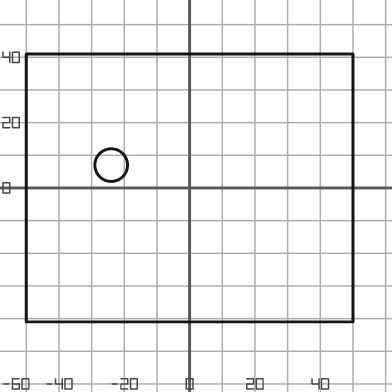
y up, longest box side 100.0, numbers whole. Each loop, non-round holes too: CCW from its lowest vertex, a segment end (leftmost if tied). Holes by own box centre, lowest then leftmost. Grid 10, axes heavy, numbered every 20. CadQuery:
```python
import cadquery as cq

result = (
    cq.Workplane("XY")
    .moveTo(-50.0, -41.0)
    .lineTo(50.0, -41.0)
    .lineTo(50.0, 41.0)
    .lineTo(-50.0, 41.0)
    .close()
    .moveTo(-24.0, 7.0)
    .circle(5.0)
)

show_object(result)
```